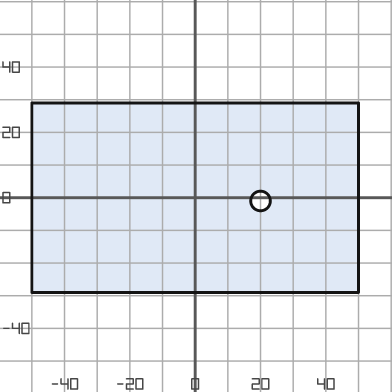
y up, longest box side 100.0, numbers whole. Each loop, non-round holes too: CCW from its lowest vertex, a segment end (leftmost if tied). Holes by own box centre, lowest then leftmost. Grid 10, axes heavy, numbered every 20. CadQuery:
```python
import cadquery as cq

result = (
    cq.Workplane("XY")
    .moveTo(-50.0, -29.0)
    .lineTo(50.0, -29.0)
    .lineTo(50.0, 29.0)
    .lineTo(-50.0, 29.0)
    .close()
    .moveTo(20.0, -1.0)
    .circle(3.0)
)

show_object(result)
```